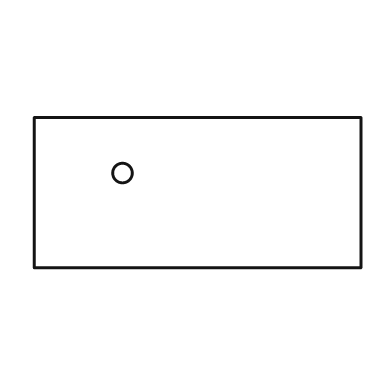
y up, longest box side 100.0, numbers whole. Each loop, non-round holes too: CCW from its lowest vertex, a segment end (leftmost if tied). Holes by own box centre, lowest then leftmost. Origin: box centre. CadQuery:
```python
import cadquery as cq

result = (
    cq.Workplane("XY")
    .moveTo(-50.0, -23.0)
    .lineTo(50.0, -23.0)
    .lineTo(50.0, 23.0)
    .lineTo(-50.0, 23.0)
    .close()
    .moveTo(-23.0, 6.0)
    .circle(3.0)
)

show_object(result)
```